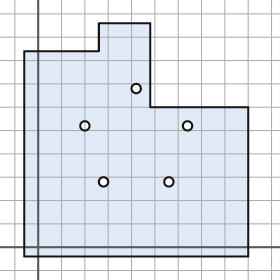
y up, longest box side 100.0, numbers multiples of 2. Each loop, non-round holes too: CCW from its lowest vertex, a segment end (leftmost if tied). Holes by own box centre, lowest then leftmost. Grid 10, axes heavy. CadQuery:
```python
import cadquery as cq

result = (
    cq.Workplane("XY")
    .moveTo(-6.0, -4.0)
    .lineTo(90.0, -4.0)
    .lineTo(90.0, 60.0)
    .lineTo(48.0, 60.0)
    .lineTo(48.0, 96.0)
    .lineTo(26.0, 96.0)
    .lineTo(26.0, 84.0)
    .lineTo(-6.0, 84.0)
    .close()
    .moveTo(28.0, 28.0)
    .circle(2.0)
    .moveTo(56.0, 28.0)
    .circle(2.0)
    .moveTo(20.0, 52.0)
    .circle(2.0)
    .moveTo(64.0, 52.0)
    .circle(2.0)
    .moveTo(42.0, 68.0)
    .circle(2.0)
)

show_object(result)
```